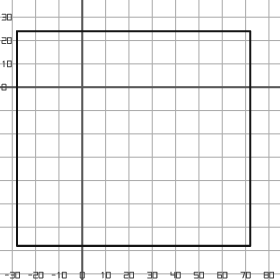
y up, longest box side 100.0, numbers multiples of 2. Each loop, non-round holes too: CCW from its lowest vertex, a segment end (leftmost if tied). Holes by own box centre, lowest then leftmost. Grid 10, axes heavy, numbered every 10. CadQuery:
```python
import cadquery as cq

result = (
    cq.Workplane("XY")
    .moveTo(-28.0, -68.0)
    .lineTo(72.0, -68.0)
    .lineTo(72.0, 24.0)
    .lineTo(-28.0, 24.0)
    .close()
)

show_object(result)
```